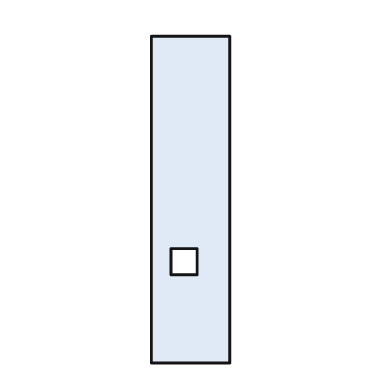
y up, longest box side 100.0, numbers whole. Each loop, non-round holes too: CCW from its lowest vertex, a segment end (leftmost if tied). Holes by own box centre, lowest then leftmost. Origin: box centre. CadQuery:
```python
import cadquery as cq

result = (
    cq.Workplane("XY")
    .moveTo(-12.0, -50.0)
    .lineTo(12.0, -50.0)
    .lineTo(12.0, 50.0)
    .lineTo(-12.0, 50.0)
    .close()
    .moveTo(-6.0, -23.0)
    .lineTo(2.0, -23.0)
    .lineTo(2.0, -15.0)
    .lineTo(-6.0, -15.0)
    .close()
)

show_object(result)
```